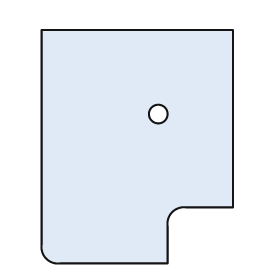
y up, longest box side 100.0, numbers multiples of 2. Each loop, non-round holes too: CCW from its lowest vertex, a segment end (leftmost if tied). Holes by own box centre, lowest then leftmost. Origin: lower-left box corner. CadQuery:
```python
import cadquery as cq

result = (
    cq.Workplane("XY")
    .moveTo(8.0, 0.0)
    .lineTo(54.0, 0.0)
    .lineTo(54.0, 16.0)
    .threePointArc((56.0, 22.0), (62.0, 24.0))
    .lineTo(82.0, 24.0)
    .lineTo(82.0, 100.0)
    .lineTo(0.0, 100.0)
    .lineTo(0.0, 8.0)
    .threePointArc((2.0, 2.0), (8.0, 0.0))
    .close()
    .moveTo(50.0, 64.0)
    .circle(4.0)
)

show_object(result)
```